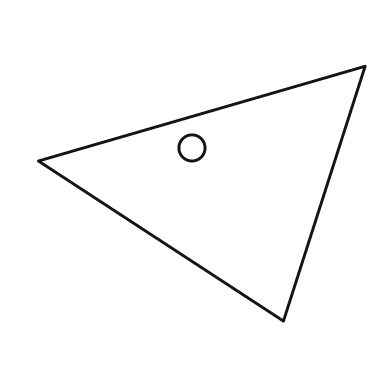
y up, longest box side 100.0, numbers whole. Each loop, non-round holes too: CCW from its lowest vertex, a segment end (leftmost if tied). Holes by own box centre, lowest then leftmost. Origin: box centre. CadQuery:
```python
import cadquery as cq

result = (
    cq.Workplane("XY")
    .moveTo(25.0, -39.0)
    .lineTo(50.0, 39.0)
    .lineTo(-50.0, 10.0)
    .close()
    .moveTo(-3.0, 14.0)
    .circle(4.0)
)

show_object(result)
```